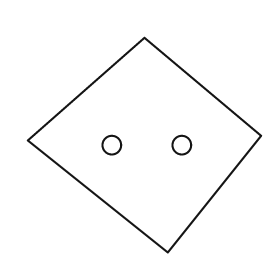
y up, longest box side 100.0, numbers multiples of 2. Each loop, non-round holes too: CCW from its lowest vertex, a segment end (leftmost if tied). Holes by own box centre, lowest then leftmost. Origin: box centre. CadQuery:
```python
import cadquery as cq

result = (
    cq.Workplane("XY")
    .moveTo(10.0, -46.0)
    .lineTo(50.0, 4.0)
    .lineTo(0.0, 46.0)
    .lineTo(-50.0, 2.0)
    .close()
    .moveTo(-14.0, 0.0)
    .circle(4.0)
    .moveTo(16.0, 0.0)
    .circle(4.0)
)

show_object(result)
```